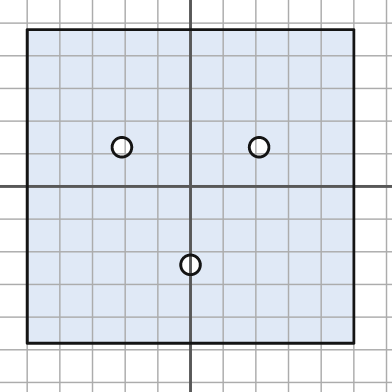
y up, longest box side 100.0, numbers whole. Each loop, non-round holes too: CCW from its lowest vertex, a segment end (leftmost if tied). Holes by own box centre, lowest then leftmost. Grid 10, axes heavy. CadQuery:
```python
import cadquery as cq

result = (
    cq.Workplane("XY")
    .moveTo(-50.0, -48.0)
    .lineTo(50.0, -48.0)
    .lineTo(50.0, 48.0)
    .lineTo(-50.0, 48.0)
    .close()
    .moveTo(0.0, -24.0)
    .circle(3.0)
    .moveTo(-21.0, 12.0)
    .circle(3.0)
    .moveTo(21.0, 12.0)
    .circle(3.0)
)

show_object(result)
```